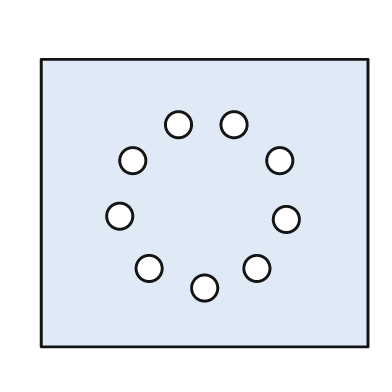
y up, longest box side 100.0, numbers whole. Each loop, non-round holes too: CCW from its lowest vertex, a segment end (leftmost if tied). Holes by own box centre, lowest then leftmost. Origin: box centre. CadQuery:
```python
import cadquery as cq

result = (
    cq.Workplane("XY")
    .moveTo(-50.0, -44.0)
    .lineTo(50.0, -44.0)
    .lineTo(50.0, 44.0)
    .lineTo(-50.0, 44.0)
    .close()
    .moveTo(0.0, -26.0)
    .circle(4.0)
    .moveTo(-17.0, -20.0)
    .circle(4.0)
    .moveTo(16.0, -20.0)
    .circle(4.0)
    .moveTo(25.0, -5.0)
    .circle(4.0)
    .moveTo(-26.0, -4.0)
    .circle(4.0)
    .moveTo(-22.0, 13.0)
    .circle(4.0)
    .moveTo(23.0, 13.0)
    .circle(4.0)
    .moveTo(-8.0, 24.0)
    .circle(4.0)
    .moveTo(9.0, 24.0)
    .circle(4.0)
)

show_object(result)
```